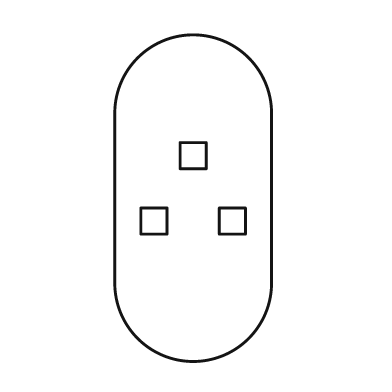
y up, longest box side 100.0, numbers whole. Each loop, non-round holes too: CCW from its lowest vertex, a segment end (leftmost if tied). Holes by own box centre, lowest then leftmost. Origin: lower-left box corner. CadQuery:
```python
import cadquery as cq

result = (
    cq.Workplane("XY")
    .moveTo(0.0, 24.0)
    .threePointArc((24.0, 0.0), (48.0, 24.0))
    .lineTo(48.0, 76.0)
    .threePointArc((24.0, 100.0), (0.0, 76.0))
    .close()
    .moveTo(8.0, 39.0)
    .lineTo(16.0, 39.0)
    .lineTo(16.0, 47.0)
    .lineTo(8.0, 47.0)
    .close()
    .moveTo(32.0, 39.0)
    .lineTo(40.0, 39.0)
    .lineTo(40.0, 47.0)
    .lineTo(32.0, 47.0)
    .close()
    .moveTo(20.0, 59.0)
    .lineTo(28.0, 59.0)
    .lineTo(28.0, 67.0)
    .lineTo(20.0, 67.0)
    .close()
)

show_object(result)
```